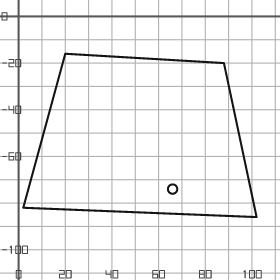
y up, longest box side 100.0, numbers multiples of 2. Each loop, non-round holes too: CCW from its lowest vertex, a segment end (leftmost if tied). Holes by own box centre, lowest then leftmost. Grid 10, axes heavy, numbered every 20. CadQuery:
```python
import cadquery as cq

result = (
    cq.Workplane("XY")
    .moveTo(102.0, -86.0)
    .lineTo(88.0, -20.0)
    .lineTo(20.0, -16.0)
    .lineTo(2.0, -82.0)
    .close()
    .moveTo(66.0, -74.0)
    .circle(2.0)
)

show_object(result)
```